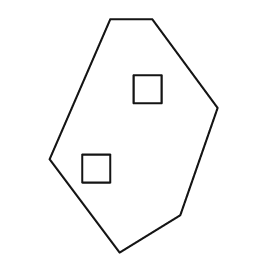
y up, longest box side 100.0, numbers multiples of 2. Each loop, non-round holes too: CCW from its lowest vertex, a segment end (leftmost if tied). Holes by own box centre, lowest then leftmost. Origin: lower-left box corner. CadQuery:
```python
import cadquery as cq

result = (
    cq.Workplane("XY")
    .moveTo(30.0, 0.0)
    .lineTo(56.0, 16.0)
    .lineTo(72.0, 62.0)
    .lineTo(44.0, 100.0)
    .lineTo(26.0, 100.0)
    .lineTo(0.0, 40.0)
    .close()
    .moveTo(14.0, 30.0)
    .lineTo(26.0, 30.0)
    .lineTo(26.0, 42.0)
    .lineTo(14.0, 42.0)
    .close()
    .moveTo(36.0, 64.0)
    .lineTo(48.0, 64.0)
    .lineTo(48.0, 76.0)
    .lineTo(36.0, 76.0)
    .close()
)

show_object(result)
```